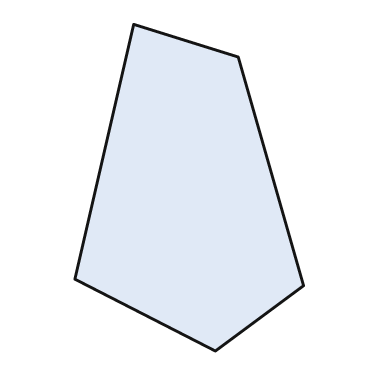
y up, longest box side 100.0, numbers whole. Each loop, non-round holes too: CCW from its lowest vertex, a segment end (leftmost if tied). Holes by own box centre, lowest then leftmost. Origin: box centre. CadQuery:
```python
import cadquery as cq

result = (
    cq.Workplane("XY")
    .moveTo(8.0, -50.0)
    .lineTo(35.0, -30.0)
    .lineTo(15.0, 40.0)
    .lineTo(-17.0, 50.0)
    .lineTo(-35.0, -28.0)
    .close()
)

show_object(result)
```